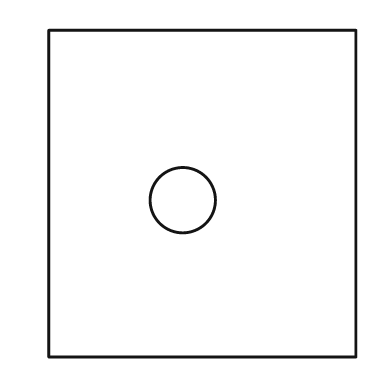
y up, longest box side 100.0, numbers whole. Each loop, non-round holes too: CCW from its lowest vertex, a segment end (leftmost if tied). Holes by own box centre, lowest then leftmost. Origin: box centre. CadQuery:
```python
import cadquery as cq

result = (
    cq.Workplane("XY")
    .moveTo(-47.0, -50.0)
    .lineTo(47.0, -50.0)
    .lineTo(47.0, 50.0)
    .lineTo(-47.0, 50.0)
    .close()
    .moveTo(-6.0, -2.0)
    .circle(10.0)
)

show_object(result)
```